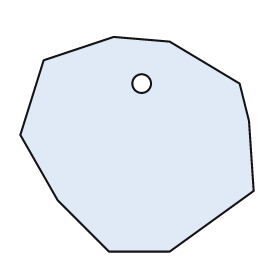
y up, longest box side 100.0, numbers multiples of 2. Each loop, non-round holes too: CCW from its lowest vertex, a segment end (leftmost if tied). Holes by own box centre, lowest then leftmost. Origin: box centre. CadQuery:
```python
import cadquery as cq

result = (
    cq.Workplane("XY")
    .moveTo(-12.0, -46.0)
    .lineTo(14.0, -46.0)
    .lineTo(50.0, -20.0)
    .lineTo(48.0, 10.0)
    .lineTo(44.0, 26.0)
    .lineTo(14.0, 44.0)
    .lineTo(-10.0, 46.0)
    .lineTo(-40.0, 36.0)
    .lineTo(-50.0, 4.0)
    .lineTo(-34.0, -24.0)
    .close()
    .moveTo(2.0, 26.0)
    .circle(4.0)
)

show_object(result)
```